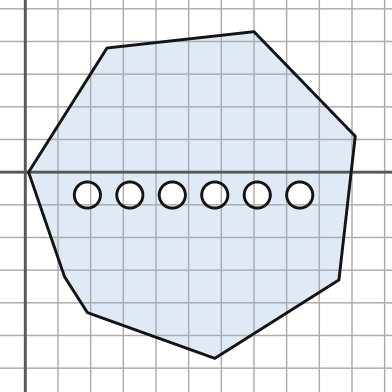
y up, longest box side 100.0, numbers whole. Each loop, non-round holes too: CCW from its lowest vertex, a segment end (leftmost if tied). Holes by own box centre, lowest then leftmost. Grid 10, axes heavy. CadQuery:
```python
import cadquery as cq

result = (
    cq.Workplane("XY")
    .moveTo(58.0, -57.0)
    .lineTo(96.0, -33.0)
    .lineTo(101.0, 11.0)
    .lineTo(70.0, 43.0)
    .lineTo(25.0, 38.0)
    .lineTo(1.0, 0.0)
    .lineTo(12.0, -32.0)
    .lineTo(19.0, -43.0)
    .close()
    .moveTo(19.0, -7.0)
    .circle(4.0)
    .moveTo(32.0, -7.0)
    .circle(4.0)
    .moveTo(45.0, -7.0)
    .circle(4.0)
    .moveTo(58.0, -7.0)
    .circle(4.0)
    .moveTo(71.0, -7.0)
    .circle(4.0)
    .moveTo(84.0, -7.0)
    .circle(4.0)
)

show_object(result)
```